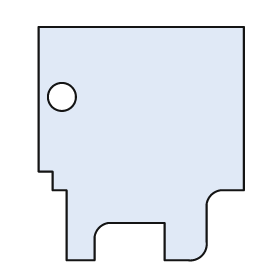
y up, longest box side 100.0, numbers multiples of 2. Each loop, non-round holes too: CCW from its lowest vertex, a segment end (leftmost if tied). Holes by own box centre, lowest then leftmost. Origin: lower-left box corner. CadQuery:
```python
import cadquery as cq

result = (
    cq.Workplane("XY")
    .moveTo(12.0, 0.0)
    .lineTo(24.0, 0.0)
    .lineTo(24.0, 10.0)
    .threePointArc((26.0, 14.0), (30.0, 16.0))
    .lineTo(54.0, 16.0)
    .lineTo(54.0, 0.0)
    .lineTo(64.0, 0.0)
    .threePointArc((70.0, 2.0), (72.0, 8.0))
    .lineTo(72.0, 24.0)
    .threePointArc((74.0, 28.0), (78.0, 30.0))
    .lineTo(88.0, 30.0)
    .lineTo(88.0, 100.0)
    .lineTo(0.0, 100.0)
    .lineTo(0.0, 38.0)
    .lineTo(6.0, 38.0)
    .lineTo(6.0, 30.0)
    .lineTo(12.0, 30.0)
    .close()
    .moveTo(10.0, 70.0)
    .circle(6.0)
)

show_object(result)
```